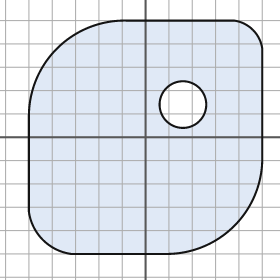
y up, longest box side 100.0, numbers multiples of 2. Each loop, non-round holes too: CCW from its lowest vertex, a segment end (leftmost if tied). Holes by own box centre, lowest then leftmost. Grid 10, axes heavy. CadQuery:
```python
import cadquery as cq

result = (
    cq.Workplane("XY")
    .moveTo(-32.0, -50.0)
    .lineTo(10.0, -50.0)
    .threePointArc((38.0, -38.0), (50.0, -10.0))
    .lineTo(50.0, 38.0)
    .threePointArc((46.0, 46.0), (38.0, 50.0))
    .lineTo(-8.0, 50.0)
    .threePointArc((-38.0, 38.0), (-50.0, 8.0))
    .lineTo(-50.0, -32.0)
    .threePointArc((-44.0, -44.0), (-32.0, -50.0))
    .close()
    .moveTo(16.0, 14.0)
    .circle(10.0)
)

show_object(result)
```